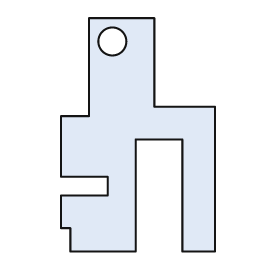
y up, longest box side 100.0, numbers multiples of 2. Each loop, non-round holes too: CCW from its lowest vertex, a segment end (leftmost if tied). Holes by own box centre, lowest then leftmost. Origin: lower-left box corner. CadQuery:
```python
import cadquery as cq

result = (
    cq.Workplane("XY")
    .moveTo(4.0, 0.0)
    .lineTo(32.0, 0.0)
    .lineTo(32.0, 48.0)
    .lineTo(52.0, 48.0)
    .lineTo(52.0, 0.0)
    .lineTo(66.0, 0.0)
    .lineTo(66.0, 62.0)
    .lineTo(40.0, 62.0)
    .lineTo(40.0, 100.0)
    .lineTo(12.0, 100.0)
    .lineTo(12.0, 58.0)
    .lineTo(0.0, 58.0)
    .lineTo(0.0, 32.0)
    .lineTo(20.0, 32.0)
    .lineTo(20.0, 24.0)
    .lineTo(0.0, 24.0)
    .lineTo(0.0, 10.0)
    .lineTo(4.0, 10.0)
    .close()
    .moveTo(22.0, 90.0)
    .circle(6.0)
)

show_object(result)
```